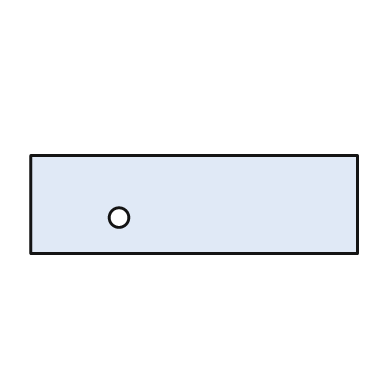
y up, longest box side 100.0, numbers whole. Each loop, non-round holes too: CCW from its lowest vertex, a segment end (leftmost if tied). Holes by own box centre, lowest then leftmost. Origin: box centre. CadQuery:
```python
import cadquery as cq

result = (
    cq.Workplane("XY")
    .moveTo(-50.0, -15.0)
    .lineTo(50.0, -15.0)
    .lineTo(50.0, 15.0)
    .lineTo(-50.0, 15.0)
    .close()
    .moveTo(-23.0, -4.0)
    .circle(3.0)
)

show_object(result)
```